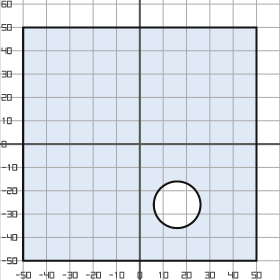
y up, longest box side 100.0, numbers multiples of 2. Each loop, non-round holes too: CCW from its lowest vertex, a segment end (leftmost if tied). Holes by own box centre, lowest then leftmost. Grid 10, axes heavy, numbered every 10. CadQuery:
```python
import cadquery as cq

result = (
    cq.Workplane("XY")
    .moveTo(-50.0, -50.0)
    .lineTo(50.0, -50.0)
    .lineTo(50.0, 50.0)
    .lineTo(-50.0, 50.0)
    .close()
    .moveTo(16.0, -26.0)
    .circle(10.0)
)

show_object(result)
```